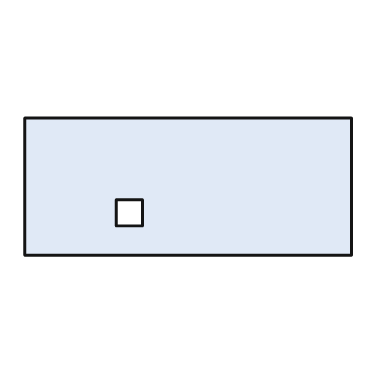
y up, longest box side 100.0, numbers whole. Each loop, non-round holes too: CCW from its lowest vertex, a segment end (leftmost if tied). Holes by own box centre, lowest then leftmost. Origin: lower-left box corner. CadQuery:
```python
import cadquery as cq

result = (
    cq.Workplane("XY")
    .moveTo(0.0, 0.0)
    .lineTo(100.0, 0.0)
    .lineTo(100.0, 42.0)
    .lineTo(0.0, 42.0)
    .close()
    .moveTo(28.0, 9.0)
    .lineTo(36.0, 9.0)
    .lineTo(36.0, 17.0)
    .lineTo(28.0, 17.0)
    .close()
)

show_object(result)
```